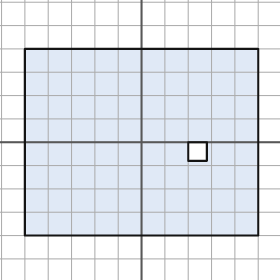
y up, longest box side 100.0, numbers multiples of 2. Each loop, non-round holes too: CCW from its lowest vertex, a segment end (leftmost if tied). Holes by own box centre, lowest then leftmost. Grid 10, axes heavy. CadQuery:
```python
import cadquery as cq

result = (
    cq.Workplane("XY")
    .moveTo(-50.0, -40.0)
    .lineTo(50.0, -40.0)
    .lineTo(50.0, 40.0)
    .lineTo(-50.0, 40.0)
    .close()
    .moveTo(20.0, -8.0)
    .lineTo(28.0, -8.0)
    .lineTo(28.0, 0.0)
    .lineTo(20.0, 0.0)
    .close()
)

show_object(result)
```